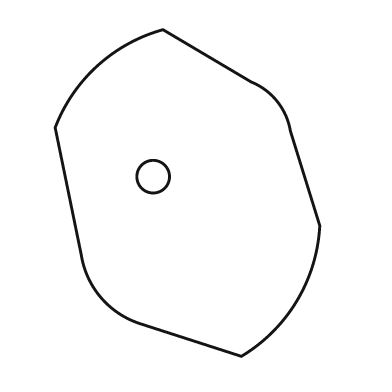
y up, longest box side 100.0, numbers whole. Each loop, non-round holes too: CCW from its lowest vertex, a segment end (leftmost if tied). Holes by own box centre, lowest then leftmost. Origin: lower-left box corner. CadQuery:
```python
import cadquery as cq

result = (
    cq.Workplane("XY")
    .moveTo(57.0, 0.0)
    .threePointArc((74.0, 17.0), (81.0, 40.0))
    .lineTo(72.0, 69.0)
    .threePointArc((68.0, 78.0), (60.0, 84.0))
    .lineTo(33.0, 100.0)
    .threePointArc((13.0, 89.0), (0.0, 70.0))
    .lineTo(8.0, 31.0)
    .threePointArc((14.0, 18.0), (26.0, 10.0))
    .close()
    .moveTo(30.0, 55.0)
    .circle(5.0)
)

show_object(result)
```